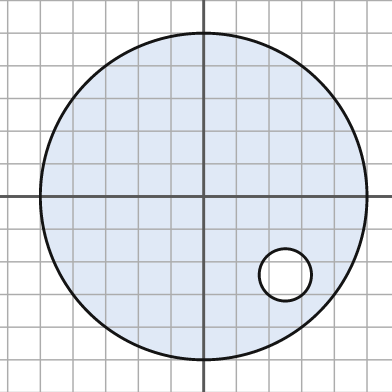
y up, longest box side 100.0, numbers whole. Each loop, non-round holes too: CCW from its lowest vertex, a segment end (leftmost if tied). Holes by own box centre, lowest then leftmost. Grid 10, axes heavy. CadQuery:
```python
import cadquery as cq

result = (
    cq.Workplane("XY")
    .moveTo(0.0, 0.0)
    .circle(50.0)
    .moveTo(25.0, -24.0)
    .circle(8.0)
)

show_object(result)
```